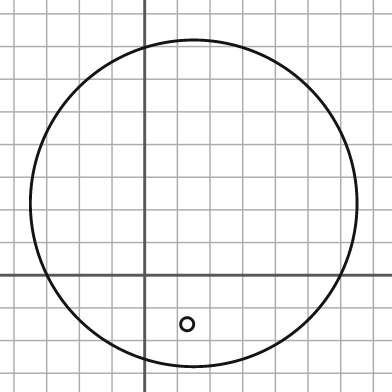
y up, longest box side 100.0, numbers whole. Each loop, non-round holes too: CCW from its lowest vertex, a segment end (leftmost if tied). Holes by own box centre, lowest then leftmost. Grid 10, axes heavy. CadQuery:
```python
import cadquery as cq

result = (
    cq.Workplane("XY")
    .moveTo(15.0, 22.0)
    .circle(50.0)
    .moveTo(13.0, -15.0)
    .circle(2.0)
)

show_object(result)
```